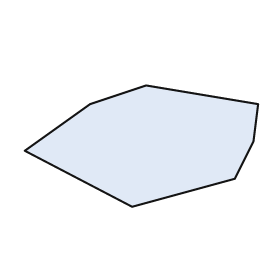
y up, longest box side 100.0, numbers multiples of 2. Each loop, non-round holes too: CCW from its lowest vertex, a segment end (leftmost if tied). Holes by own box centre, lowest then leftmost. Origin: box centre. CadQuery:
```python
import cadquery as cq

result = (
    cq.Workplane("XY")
    .moveTo(-4.0, -26.0)
    .lineTo(40.0, -14.0)
    .lineTo(48.0, 2.0)
    .lineTo(50.0, 18.0)
    .lineTo(2.0, 26.0)
    .lineTo(-22.0, 18.0)
    .lineTo(-50.0, -2.0)
    .close()
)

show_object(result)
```